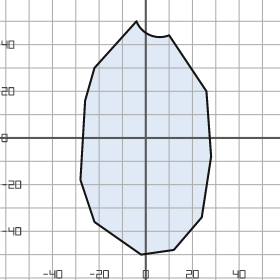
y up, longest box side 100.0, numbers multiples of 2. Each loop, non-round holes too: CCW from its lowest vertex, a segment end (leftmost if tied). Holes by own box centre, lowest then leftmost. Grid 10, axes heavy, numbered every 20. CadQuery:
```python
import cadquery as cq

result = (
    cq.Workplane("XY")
    .moveTo(-2.0, -50.0)
    .lineTo(12.0, -48.0)
    .lineTo(24.0, -34.0)
    .lineTo(28.0, -8.0)
    .lineTo(26.0, 20.0)
    .lineTo(10.0, 44.0)
    .threePointArc((2.0, 44.0), (-4.0, 50.0))
    .lineTo(-22.0, 30.0)
    .lineTo(-26.0, 16.0)
    .lineTo(-28.0, -18.0)
    .lineTo(-22.0, -36.0)
    .close()
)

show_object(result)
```